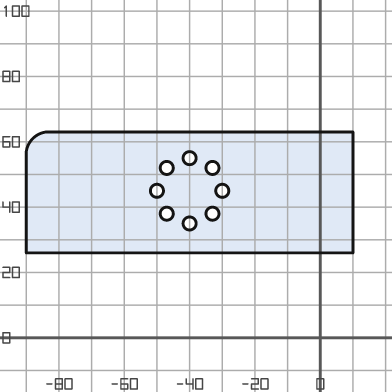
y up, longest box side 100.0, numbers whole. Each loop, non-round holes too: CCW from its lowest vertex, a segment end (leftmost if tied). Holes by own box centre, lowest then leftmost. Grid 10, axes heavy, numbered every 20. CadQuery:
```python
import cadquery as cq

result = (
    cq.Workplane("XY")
    .moveTo(-90.0, 26.0)
    .lineTo(10.0, 26.0)
    .lineTo(10.0, 63.0)
    .lineTo(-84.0, 63.0)
    .threePointArc((-88.0, 61.0), (-90.0, 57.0))
    .close()
    .moveTo(-40.0, 35.0)
    .circle(2.0)
    .moveTo(-47.0, 38.0)
    .circle(2.0)
    .moveTo(-33.0, 38.0)
    .circle(2.0)
    .moveTo(-50.0, 45.0)
    .circle(2.0)
    .moveTo(-30.0, 45.0)
    .circle(2.0)
    .moveTo(-47.0, 52.0)
    .circle(2.0)
    .moveTo(-33.0, 52.0)
    .circle(2.0)
    .moveTo(-40.0, 55.0)
    .circle(2.0)
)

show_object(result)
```